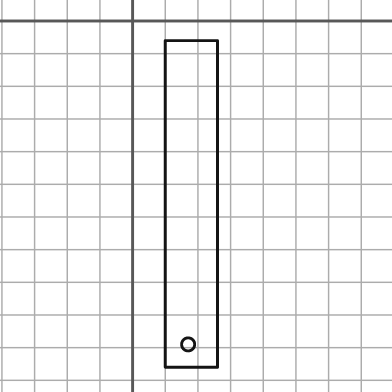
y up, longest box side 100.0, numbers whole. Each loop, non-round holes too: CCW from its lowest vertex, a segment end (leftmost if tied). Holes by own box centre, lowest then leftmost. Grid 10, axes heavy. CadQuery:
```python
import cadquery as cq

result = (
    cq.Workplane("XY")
    .moveTo(10.0, -106.0)
    .lineTo(26.0, -106.0)
    .lineTo(26.0, -6.0)
    .lineTo(10.0, -6.0)
    .close()
    .moveTo(17.0, -99.0)
    .circle(2.0)
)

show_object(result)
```